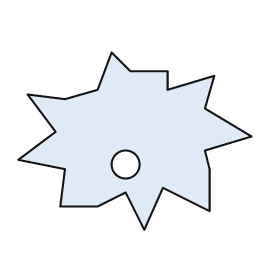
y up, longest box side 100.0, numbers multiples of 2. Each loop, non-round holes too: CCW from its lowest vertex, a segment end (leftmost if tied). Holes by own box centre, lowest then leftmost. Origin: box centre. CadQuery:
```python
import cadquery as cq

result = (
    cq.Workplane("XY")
    .moveTo(4.0, -38.0)
    .lineTo(12.0, -20.0)
    .lineTo(32.0, -30.0)
    .lineTo(32.0, -12.0)
    .lineTo(30.0, -4.0)
    .lineTo(50.0, 2.0)
    .lineTo(30.0, 14.0)
    .lineTo(34.0, 28.0)
    .lineTo(14.0, 22.0)
    .lineTo(14.0, 30.0)
    .lineTo(-2.0, 30.0)
    .lineTo(-10.0, 38.0)
    .lineTo(-16.0, 22.0)
    .lineTo(-30.0, 18.0)
    .lineTo(-46.0, 20.0)
    .lineTo(-34.0, 4.0)
    .lineTo(-50.0, -8.0)
    .lineTo(-30.0, -12.0)
    .lineTo(-32.0, -28.0)
    .lineTo(-16.0, -28.0)
    .lineTo(-4.0, -22.0)
    .close()
    .moveTo(-4.0, -10.0)
    .circle(6.0)
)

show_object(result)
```